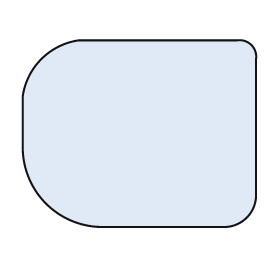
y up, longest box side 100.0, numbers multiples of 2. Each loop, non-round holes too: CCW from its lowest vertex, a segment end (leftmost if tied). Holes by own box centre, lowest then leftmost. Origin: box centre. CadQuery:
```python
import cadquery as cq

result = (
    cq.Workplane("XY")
    .moveTo(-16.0, -40.0)
    .lineTo(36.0, -40.0)
    .threePointArc((46.0, -36.0), (50.0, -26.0))
    .lineTo(50.0, 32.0)
    .threePointArc((48.0, 38.0), (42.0, 40.0))
    .lineTo(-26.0, 40.0)
    .threePointArc((-42.0, 32.0), (-50.0, 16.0))
    .lineTo(-50.0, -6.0)
    .threePointArc((-40.0, -30.0), (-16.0, -40.0))
    .close()
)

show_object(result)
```